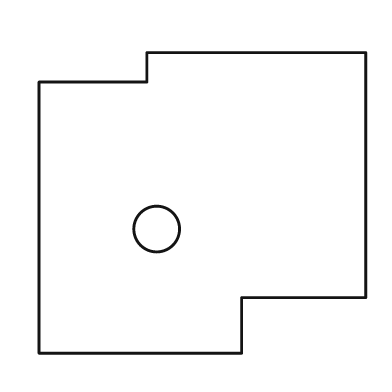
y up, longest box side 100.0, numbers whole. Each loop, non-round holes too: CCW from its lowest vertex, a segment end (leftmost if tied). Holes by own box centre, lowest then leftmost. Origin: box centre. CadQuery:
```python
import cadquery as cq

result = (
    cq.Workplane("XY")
    .moveTo(-50.0, -46.0)
    .lineTo(12.0, -46.0)
    .lineTo(12.0, -29.0)
    .lineTo(50.0, -29.0)
    .lineTo(50.0, 46.0)
    .lineTo(-17.0, 46.0)
    .lineTo(-17.0, 37.0)
    .lineTo(-50.0, 37.0)
    .close()
    .moveTo(-14.0, -8.0)
    .circle(7.0)
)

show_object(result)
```